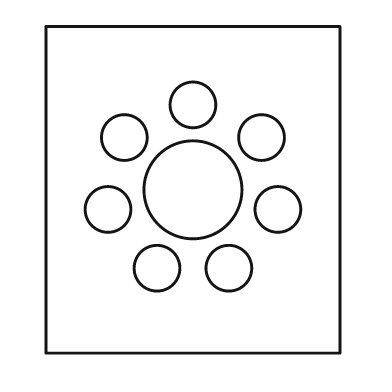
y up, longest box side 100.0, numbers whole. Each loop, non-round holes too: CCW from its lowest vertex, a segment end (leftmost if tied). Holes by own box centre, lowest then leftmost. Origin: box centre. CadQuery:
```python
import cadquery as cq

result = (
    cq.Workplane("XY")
    .moveTo(-45.0, -50.0)
    .lineTo(45.0, -50.0)
    .lineTo(45.0, 50.0)
    .lineTo(-45.0, 50.0)
    .close()
    .moveTo(-11.0, -24.0)
    .circle(7.0)
    .moveTo(11.0, -24.0)
    .circle(7.0)
    .moveTo(-26.0, -6.0)
    .circle(7.0)
    .moveTo(26.0, -6.0)
    .circle(7.0)
    .moveTo(0.0, 0.0)
    .circle(15.0)
    .moveTo(-21.0, 16.0)
    .circle(7.0)
    .moveTo(21.0, 16.0)
    .circle(7.0)
    .moveTo(0.0, 26.0)
    .circle(7.0)
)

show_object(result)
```